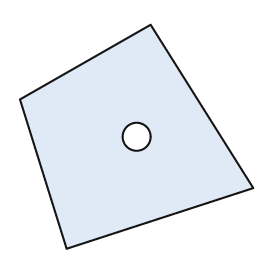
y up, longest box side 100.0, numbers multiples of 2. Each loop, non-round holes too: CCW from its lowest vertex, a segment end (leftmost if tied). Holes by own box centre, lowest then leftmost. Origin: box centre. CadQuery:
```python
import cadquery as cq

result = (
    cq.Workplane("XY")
    .moveTo(-30.0, -48.0)
    .lineTo(50.0, -22.0)
    .lineTo(6.0, 48.0)
    .lineTo(-50.0, 16.0)
    .close()
    .moveTo(0.0, 0.0)
    .circle(6.0)
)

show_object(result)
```